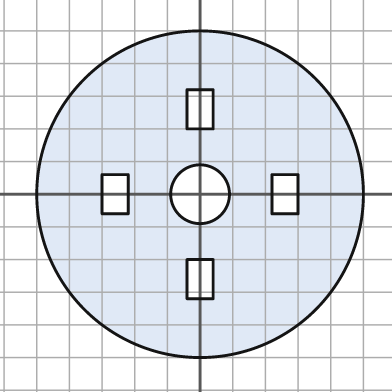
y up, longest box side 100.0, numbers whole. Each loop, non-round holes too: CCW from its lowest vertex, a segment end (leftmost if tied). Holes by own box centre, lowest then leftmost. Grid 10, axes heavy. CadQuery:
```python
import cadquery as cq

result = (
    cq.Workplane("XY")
    .moveTo(0.0, 0.0)
    .circle(50.0)
    .moveTo(-4.0, -32.0)
    .lineTo(4.0, -32.0)
    .lineTo(4.0, -20.0)
    .lineTo(-4.0, -20.0)
    .close()
    .moveTo(-30.0, -6.0)
    .lineTo(-22.0, -6.0)
    .lineTo(-22.0, 6.0)
    .lineTo(-30.0, 6.0)
    .close()
    .moveTo(0.0, 0.0)
    .circle(9.0)
    .moveTo(22.0, -6.0)
    .lineTo(30.0, -6.0)
    .lineTo(30.0, 6.0)
    .lineTo(22.0, 6.0)
    .close()
    .moveTo(-4.0, 20.0)
    .lineTo(4.0, 20.0)
    .lineTo(4.0, 32.0)
    .lineTo(-4.0, 32.0)
    .close()
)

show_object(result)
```